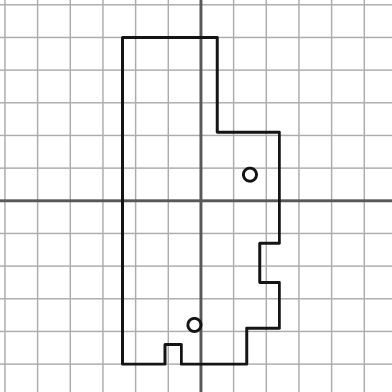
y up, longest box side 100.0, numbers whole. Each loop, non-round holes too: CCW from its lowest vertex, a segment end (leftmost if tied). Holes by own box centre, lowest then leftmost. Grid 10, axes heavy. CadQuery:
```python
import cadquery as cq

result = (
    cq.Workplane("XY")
    .moveTo(-24.0, -50.0)
    .lineTo(-11.0, -50.0)
    .lineTo(-11.0, -44.0)
    .lineTo(-6.0, -44.0)
    .lineTo(-6.0, -50.0)
    .lineTo(14.0, -50.0)
    .lineTo(14.0, -39.0)
    .lineTo(24.0, -39.0)
    .lineTo(24.0, -25.0)
    .lineTo(18.0, -25.0)
    .lineTo(18.0, -13.0)
    .lineTo(24.0, -13.0)
    .lineTo(24.0, 21.0)
    .lineTo(5.0, 21.0)
    .lineTo(5.0, 50.0)
    .lineTo(-24.0, 50.0)
    .close()
    .moveTo(-2.0, -38.0)
    .circle(2.0)
    .moveTo(15.0, 8.0)
    .circle(2.0)
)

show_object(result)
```